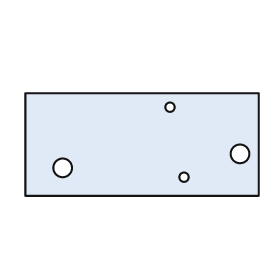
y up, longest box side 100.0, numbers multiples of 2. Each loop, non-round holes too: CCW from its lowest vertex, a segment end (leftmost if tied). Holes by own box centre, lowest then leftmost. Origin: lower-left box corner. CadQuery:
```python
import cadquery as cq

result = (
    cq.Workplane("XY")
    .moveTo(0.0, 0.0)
    .lineTo(100.0, 0.0)
    .lineTo(100.0, 44.0)
    .lineTo(0.0, 44.0)
    .close()
    .moveTo(68.0, 8.0)
    .circle(2.0)
    .moveTo(16.0, 12.0)
    .circle(4.0)
    .moveTo(92.0, 18.0)
    .circle(4.0)
    .moveTo(62.0, 38.0)
    .circle(2.0)
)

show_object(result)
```